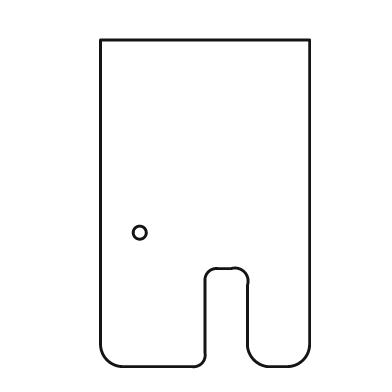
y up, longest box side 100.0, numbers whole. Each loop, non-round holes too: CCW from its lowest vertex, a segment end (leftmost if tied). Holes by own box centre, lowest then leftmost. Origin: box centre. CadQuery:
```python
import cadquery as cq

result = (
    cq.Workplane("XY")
    .moveTo(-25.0, -50.0)
    .lineTo(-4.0, -50.0)
    .threePointArc((-1.0, -49.0), (0.0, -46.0))
    .lineTo(0.0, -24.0)
    .threePointArc((1.0, -21.0), (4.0, -20.0))
    .lineTo(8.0, -20.0)
    .threePointArc((12.0, -21.0), (13.0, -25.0))
    .lineTo(13.0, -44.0)
    .threePointArc((15.0, -48.0), (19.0, -50.0))
    .lineTo(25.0, -50.0)
    .threePointArc((30.0, -48.0), (32.0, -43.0))
    .lineTo(32.0, 50.0)
    .lineTo(-32.0, 50.0)
    .lineTo(-32.0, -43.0)
    .threePointArc((-30.0, -48.0), (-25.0, -50.0))
    .close()
    .moveTo(-20.0, -9.0)
    .circle(2.0)
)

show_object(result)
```